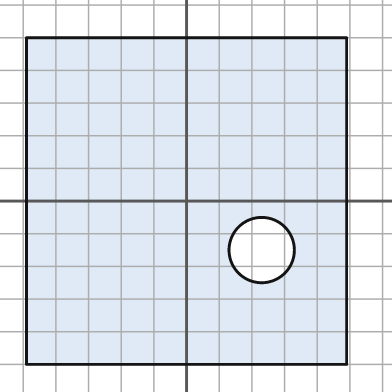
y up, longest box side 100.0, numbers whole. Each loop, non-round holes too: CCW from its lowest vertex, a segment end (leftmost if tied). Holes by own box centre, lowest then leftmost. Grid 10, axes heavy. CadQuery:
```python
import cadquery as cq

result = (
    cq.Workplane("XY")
    .moveTo(-49.0, -50.0)
    .lineTo(49.0, -50.0)
    .lineTo(49.0, 50.0)
    .lineTo(-49.0, 50.0)
    .close()
    .moveTo(23.0, -15.0)
    .circle(10.0)
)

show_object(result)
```